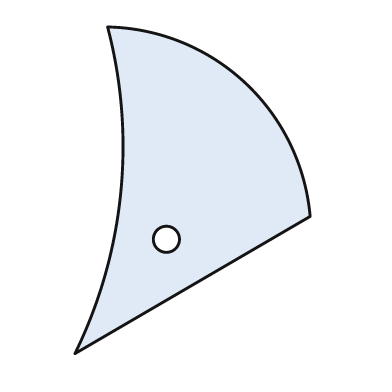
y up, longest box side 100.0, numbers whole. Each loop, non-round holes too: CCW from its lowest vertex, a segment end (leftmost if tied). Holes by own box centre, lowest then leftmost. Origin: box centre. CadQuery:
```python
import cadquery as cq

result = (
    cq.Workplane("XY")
    .moveTo(-36.0, -50.0)
    .lineTo(36.0, -8.0)
    .threePointArc((16.0, 33.0), (-26.0, 50.0))
    .threePointArc((-22.0, -1.0), (-36.0, -50.0))
    .close()
    .moveTo(-8.0, -15.0)
    .circle(4.0)
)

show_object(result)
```